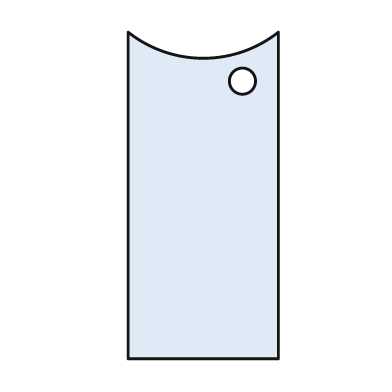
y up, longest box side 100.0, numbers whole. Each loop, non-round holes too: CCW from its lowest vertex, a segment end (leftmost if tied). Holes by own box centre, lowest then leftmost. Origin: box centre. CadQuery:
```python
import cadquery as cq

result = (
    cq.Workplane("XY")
    .moveTo(-23.0, -50.0)
    .lineTo(23.0, -50.0)
    .lineTo(23.0, 50.0)
    .threePointArc((0.0, 42.0), (-23.0, 50.0))
    .close()
    .moveTo(12.0, 35.0)
    .circle(4.0)
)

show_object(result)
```